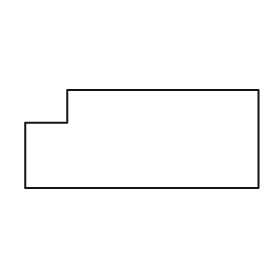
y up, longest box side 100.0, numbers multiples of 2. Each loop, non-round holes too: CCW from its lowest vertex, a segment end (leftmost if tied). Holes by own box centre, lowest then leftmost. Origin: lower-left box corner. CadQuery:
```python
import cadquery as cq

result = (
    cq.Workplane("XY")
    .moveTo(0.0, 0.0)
    .lineTo(100.0, 0.0)
    .lineTo(100.0, 42.0)
    .lineTo(18.0, 42.0)
    .lineTo(18.0, 28.0)
    .lineTo(0.0, 28.0)
    .close()
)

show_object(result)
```